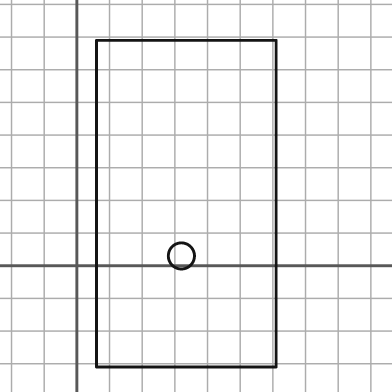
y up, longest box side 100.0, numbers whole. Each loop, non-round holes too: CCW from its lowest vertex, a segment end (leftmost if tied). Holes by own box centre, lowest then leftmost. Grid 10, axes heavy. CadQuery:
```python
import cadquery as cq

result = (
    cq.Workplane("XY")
    .moveTo(6.0, -31.0)
    .lineTo(61.0, -31.0)
    .lineTo(61.0, 69.0)
    .lineTo(6.0, 69.0)
    .close()
    .moveTo(32.0, 3.0)
    .circle(4.0)
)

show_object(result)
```